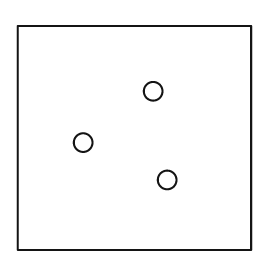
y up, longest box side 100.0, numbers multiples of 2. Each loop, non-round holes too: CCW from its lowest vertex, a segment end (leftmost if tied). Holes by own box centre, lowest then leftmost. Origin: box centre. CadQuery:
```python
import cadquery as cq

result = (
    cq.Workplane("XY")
    .moveTo(-50.0, -48.0)
    .lineTo(50.0, -48.0)
    .lineTo(50.0, 48.0)
    .lineTo(-50.0, 48.0)
    .close()
    .moveTo(14.0, -18.0)
    .circle(4.0)
    .moveTo(-22.0, -2.0)
    .circle(4.0)
    .moveTo(8.0, 20.0)
    .circle(4.0)
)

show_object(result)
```